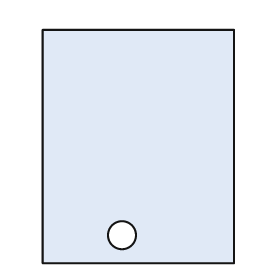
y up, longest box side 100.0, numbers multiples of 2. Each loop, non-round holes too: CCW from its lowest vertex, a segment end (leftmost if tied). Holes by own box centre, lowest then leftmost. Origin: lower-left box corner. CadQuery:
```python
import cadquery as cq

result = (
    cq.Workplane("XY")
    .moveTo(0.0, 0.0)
    .lineTo(82.0, 0.0)
    .lineTo(82.0, 100.0)
    .lineTo(0.0, 100.0)
    .close()
    .moveTo(34.0, 12.0)
    .circle(6.0)
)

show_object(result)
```